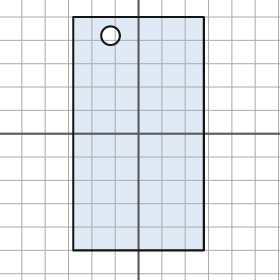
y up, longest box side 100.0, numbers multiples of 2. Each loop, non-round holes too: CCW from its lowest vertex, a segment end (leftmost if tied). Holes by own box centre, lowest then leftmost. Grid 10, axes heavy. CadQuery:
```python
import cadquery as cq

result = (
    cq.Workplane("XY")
    .moveTo(-28.0, -50.0)
    .lineTo(28.0, -50.0)
    .lineTo(28.0, 50.0)
    .lineTo(-28.0, 50.0)
    .close()
    .moveTo(-12.0, 42.0)
    .circle(4.0)
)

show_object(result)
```